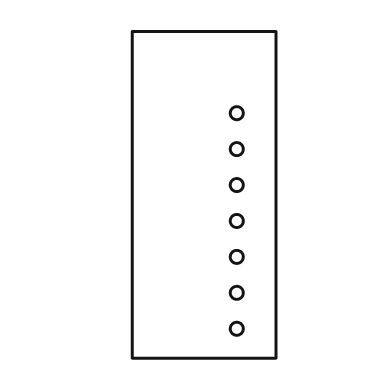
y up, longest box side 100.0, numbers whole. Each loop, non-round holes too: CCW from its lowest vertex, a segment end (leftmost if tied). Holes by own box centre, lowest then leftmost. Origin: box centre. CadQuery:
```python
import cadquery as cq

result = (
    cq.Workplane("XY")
    .moveTo(-22.0, -50.0)
    .lineTo(22.0, -50.0)
    .lineTo(22.0, 50.0)
    .lineTo(-22.0, 50.0)
    .close()
    .moveTo(10.0, -41.0)
    .circle(2.0)
    .moveTo(10.0, -30.0)
    .circle(2.0)
    .moveTo(10.0, -19.0)
    .circle(2.0)
    .moveTo(10.0, -8.0)
    .circle(2.0)
    .moveTo(10.0, 3.0)
    .circle(2.0)
    .moveTo(10.0, 14.0)
    .circle(2.0)
    .moveTo(10.0, 25.0)
    .circle(2.0)
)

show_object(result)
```